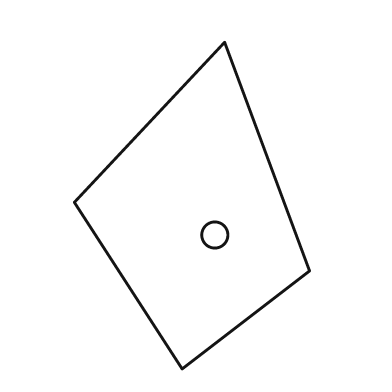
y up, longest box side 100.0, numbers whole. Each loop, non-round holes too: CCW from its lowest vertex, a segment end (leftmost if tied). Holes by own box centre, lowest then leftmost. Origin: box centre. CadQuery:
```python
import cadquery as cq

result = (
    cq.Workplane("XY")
    .moveTo(-3.0, -50.0)
    .lineTo(36.0, -20.0)
    .lineTo(10.0, 50.0)
    .lineTo(-36.0, 1.0)
    .close()
    .moveTo(7.0, -9.0)
    .circle(4.0)
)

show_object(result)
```